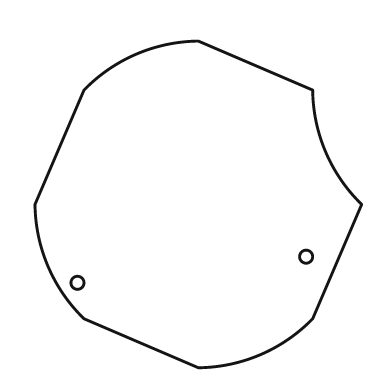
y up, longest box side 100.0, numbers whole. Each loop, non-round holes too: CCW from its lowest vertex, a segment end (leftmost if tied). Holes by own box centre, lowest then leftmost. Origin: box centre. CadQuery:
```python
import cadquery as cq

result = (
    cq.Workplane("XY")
    .moveTo(0.0, -50.0)
    .threePointArc((19.0, -46.0), (35.0, -35.0))
    .lineTo(50.0, 0.0)
    .threePointArc((39.0, 16.0), (35.0, 35.0))
    .lineTo(0.0, 50.0)
    .threePointArc((-19.0, 46.0), (-35.0, 35.0))
    .lineTo(-50.0, 0.0)
    .threePointArc((-46.0, -19.0), (-35.0, -35.0))
    .close()
    .moveTo(-37.0, -24.0)
    .circle(2.0)
    .moveTo(33.0, -16.0)
    .circle(2.0)
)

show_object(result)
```